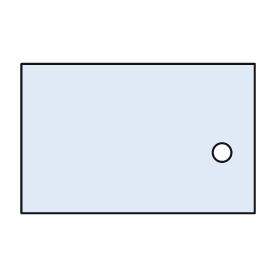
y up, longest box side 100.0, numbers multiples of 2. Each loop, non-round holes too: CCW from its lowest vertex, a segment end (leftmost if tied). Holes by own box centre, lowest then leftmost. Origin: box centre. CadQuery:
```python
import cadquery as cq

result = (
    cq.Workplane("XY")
    .moveTo(-50.0, -32.0)
    .lineTo(50.0, -32.0)
    .lineTo(50.0, 32.0)
    .lineTo(-50.0, 32.0)
    .close()
    .moveTo(36.0, -6.0)
    .circle(4.0)
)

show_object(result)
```